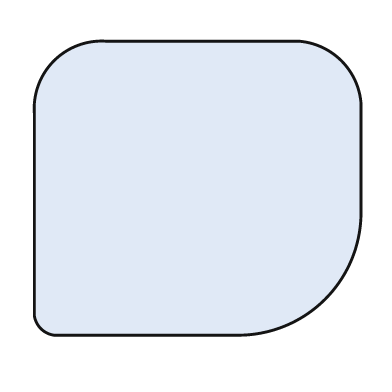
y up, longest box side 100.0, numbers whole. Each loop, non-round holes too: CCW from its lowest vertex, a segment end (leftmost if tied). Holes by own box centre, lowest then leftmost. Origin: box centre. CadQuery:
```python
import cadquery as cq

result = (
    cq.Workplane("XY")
    .moveTo(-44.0, -45.0)
    .lineTo(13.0, -45.0)
    .threePointArc((39.0, -34.0), (50.0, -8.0))
    .lineTo(50.0, 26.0)
    .threePointArc((44.0, 39.0), (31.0, 45.0))
    .lineTo(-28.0, 45.0)
    .threePointArc((-44.0, 39.0), (-50.0, 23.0))
    .lineTo(-50.0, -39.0)
    .threePointArc((-48.0, -43.0), (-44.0, -45.0))
    .close()
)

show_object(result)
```